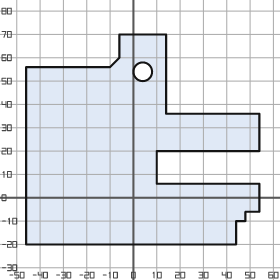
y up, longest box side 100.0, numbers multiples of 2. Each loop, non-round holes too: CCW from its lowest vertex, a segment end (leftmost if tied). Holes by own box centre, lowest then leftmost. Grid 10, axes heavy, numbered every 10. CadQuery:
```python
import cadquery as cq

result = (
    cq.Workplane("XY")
    .moveTo(-46.0, -20.0)
    .lineTo(44.0, -20.0)
    .lineTo(44.0, -10.0)
    .lineTo(48.0, -10.0)
    .lineTo(48.0, -6.0)
    .lineTo(54.0, -6.0)
    .lineTo(54.0, 6.0)
    .lineTo(10.0, 6.0)
    .lineTo(10.0, 20.0)
    .lineTo(54.0, 20.0)
    .lineTo(54.0, 36.0)
    .lineTo(14.0, 36.0)
    .lineTo(14.0, 70.0)
    .lineTo(-6.0, 70.0)
    .lineTo(-6.0, 60.0)
    .lineTo(-10.0, 56.0)
    .lineTo(-46.0, 56.0)
    .close()
    .moveTo(4.0, 54.0)
    .circle(4.0)
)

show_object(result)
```